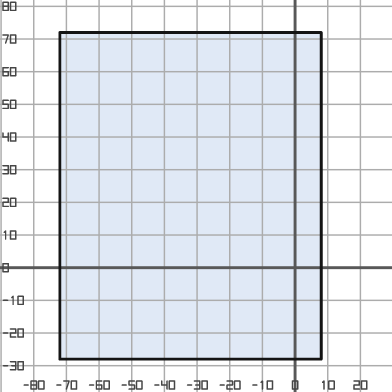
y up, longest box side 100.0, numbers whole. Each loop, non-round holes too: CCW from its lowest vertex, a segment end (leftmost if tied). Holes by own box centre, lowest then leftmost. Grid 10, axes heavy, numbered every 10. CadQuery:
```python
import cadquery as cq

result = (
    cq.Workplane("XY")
    .moveTo(-72.0, -28.0)
    .lineTo(8.0, -28.0)
    .lineTo(8.0, 72.0)
    .lineTo(-72.0, 72.0)
    .close()
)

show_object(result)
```